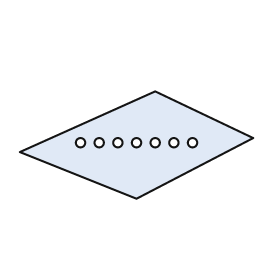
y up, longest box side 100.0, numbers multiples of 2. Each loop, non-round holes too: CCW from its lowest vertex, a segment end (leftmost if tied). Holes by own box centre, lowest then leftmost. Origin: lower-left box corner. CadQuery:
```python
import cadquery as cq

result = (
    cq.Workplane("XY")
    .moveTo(50.0, 0.0)
    .lineTo(100.0, 26.0)
    .lineTo(58.0, 46.0)
    .lineTo(0.0, 20.0)
    .close()
    .moveTo(26.0, 24.0)
    .circle(2.0)
    .moveTo(34.0, 24.0)
    .circle(2.0)
    .moveTo(42.0, 24.0)
    .circle(2.0)
    .moveTo(50.0, 24.0)
    .circle(2.0)
    .moveTo(58.0, 24.0)
    .circle(2.0)
    .moveTo(66.0, 24.0)
    .circle(2.0)
    .moveTo(74.0, 24.0)
    .circle(2.0)
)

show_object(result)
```